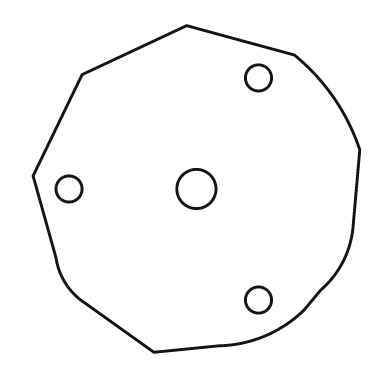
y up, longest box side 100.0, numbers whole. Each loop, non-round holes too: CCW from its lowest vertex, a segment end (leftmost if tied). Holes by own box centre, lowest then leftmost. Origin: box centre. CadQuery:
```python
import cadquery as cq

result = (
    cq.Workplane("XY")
    .moveTo(-13.0, -50.0)
    .lineTo(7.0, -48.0)
    .threePointArc((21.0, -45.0), (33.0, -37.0))
    .lineTo(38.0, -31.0)
    .threePointArc((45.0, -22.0), (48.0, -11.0))
    .lineTo(50.0, 12.0)
    .threePointArc((42.0, 28.0), (30.0, 41.0))
    .lineTo(-3.0, 50.0)
    .lineTo(-35.0, 35.0)
    .lineTo(-50.0, 4.0)
    .lineTo(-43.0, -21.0)
    .threePointArc((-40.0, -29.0), (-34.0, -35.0))
    .close()
    .moveTo(19.0, -34.0)
    .circle(4.0)
    .moveTo(-39.0, 0.0)
    .circle(4.0)
    .moveTo(0.0, 0.0)
    .circle(6.0)
    .moveTo(19.0, 34.0)
    .circle(4.0)
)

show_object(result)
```